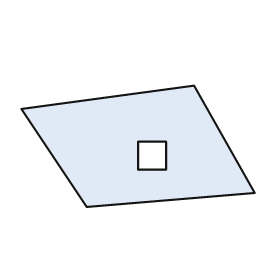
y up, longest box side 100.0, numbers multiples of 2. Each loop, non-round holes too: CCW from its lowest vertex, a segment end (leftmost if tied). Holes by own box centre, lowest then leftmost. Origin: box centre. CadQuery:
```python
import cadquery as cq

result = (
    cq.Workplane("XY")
    .moveTo(-22.0, -26.0)
    .lineTo(50.0, -20.0)
    .lineTo(24.0, 26.0)
    .lineTo(-50.0, 16.0)
    .close()
    .moveTo(0.0, -10.0)
    .lineTo(12.0, -10.0)
    .lineTo(12.0, 2.0)
    .lineTo(0.0, 2.0)
    .close()
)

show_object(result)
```